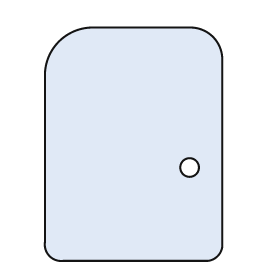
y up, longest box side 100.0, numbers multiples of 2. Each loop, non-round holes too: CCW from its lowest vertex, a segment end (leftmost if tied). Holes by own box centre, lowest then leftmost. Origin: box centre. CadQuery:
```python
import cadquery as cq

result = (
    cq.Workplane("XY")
    .moveTo(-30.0, -50.0)
    .lineTo(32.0, -50.0)
    .threePointArc((36.0, -48.0), (38.0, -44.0))
    .lineTo(38.0, 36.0)
    .threePointArc((34.0, 46.0), (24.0, 50.0))
    .lineTo(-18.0, 50.0)
    .threePointArc((-32.0, 44.0), (-38.0, 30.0))
    .lineTo(-38.0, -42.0)
    .threePointArc((-36.0, -48.0), (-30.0, -50.0))
    .close()
    .moveTo(24.0, -10.0)
    .circle(4.0)
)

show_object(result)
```